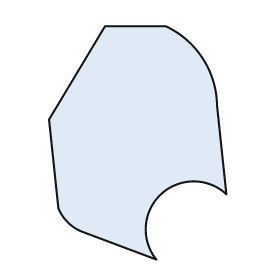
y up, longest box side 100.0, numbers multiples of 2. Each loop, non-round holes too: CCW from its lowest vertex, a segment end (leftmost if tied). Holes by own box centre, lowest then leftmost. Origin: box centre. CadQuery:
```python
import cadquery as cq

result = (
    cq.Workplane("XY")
    .moveTo(8.0, -50.0)
    .threePointArc((10.0, -22.0), (38.0, -22.0))
    .lineTo(34.0, 16.0)
    .threePointArc((28.0, 36.0), (12.0, 50.0))
    .lineTo(-14.0, 50.0)
    .lineTo(-38.0, 10.0)
    .lineTo(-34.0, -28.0)
    .threePointArc((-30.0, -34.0), (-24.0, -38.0))
    .close()
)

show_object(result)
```